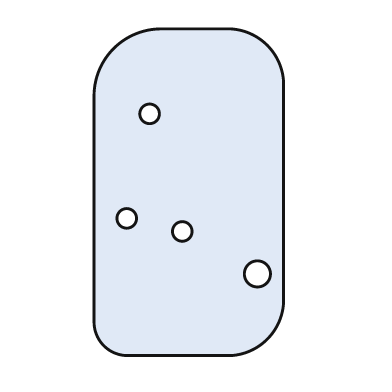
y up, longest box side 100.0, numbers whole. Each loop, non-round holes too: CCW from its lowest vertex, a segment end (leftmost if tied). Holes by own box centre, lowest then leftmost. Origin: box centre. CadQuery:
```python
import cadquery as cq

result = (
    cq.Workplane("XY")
    .moveTo(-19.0, -50.0)
    .lineTo(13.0, -50.0)
    .threePointArc((24.0, -45.0), (29.0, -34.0))
    .lineTo(29.0, 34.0)
    .threePointArc((24.0, 45.0), (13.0, 50.0))
    .lineTo(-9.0, 50.0)
    .threePointArc((-23.0, 44.0), (-29.0, 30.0))
    .lineTo(-29.0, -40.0)
    .threePointArc((-26.0, -47.0), (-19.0, -50.0))
    .close()
    .moveTo(21.0, -25.0)
    .circle(4.0)
    .moveTo(-2.0, -12.0)
    .circle(3.0)
    .moveTo(-19.0, -8.0)
    .circle(3.0)
    .moveTo(-12.0, 24.0)
    .circle(3.0)
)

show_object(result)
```